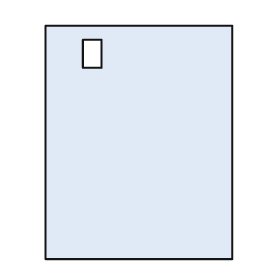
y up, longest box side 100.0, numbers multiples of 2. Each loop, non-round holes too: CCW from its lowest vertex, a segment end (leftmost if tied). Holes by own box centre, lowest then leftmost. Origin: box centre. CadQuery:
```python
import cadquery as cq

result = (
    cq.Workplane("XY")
    .moveTo(-40.0, -50.0)
    .lineTo(40.0, -50.0)
    .lineTo(40.0, 50.0)
    .lineTo(-40.0, 50.0)
    .close()
    .moveTo(-24.0, 32.0)
    .lineTo(-16.0, 32.0)
    .lineTo(-16.0, 44.0)
    .lineTo(-24.0, 44.0)
    .close()
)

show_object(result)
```